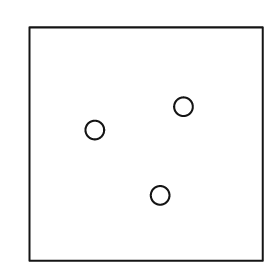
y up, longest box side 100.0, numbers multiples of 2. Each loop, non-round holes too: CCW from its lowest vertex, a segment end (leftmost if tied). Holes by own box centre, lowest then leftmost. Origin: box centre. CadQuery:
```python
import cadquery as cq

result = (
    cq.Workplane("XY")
    .moveTo(-50.0, -50.0)
    .lineTo(50.0, -50.0)
    .lineTo(50.0, 50.0)
    .lineTo(-50.0, 50.0)
    .close()
    .moveTo(6.0, -22.0)
    .circle(4.0)
    .moveTo(-22.0, 6.0)
    .circle(4.0)
    .moveTo(16.0, 16.0)
    .circle(4.0)
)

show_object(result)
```